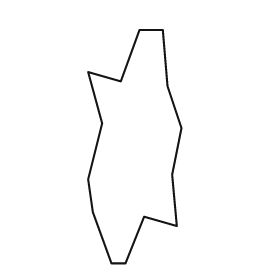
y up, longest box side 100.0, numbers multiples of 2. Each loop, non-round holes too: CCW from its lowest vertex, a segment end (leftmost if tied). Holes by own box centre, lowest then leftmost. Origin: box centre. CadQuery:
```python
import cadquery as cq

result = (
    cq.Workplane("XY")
    .moveTo(-10.0, -50.0)
    .lineTo(-4.0, -50.0)
    .lineTo(4.0, -30.0)
    .lineTo(18.0, -34.0)
    .lineTo(16.0, -12.0)
    .lineTo(20.0, 8.0)
    .lineTo(14.0, 26.0)
    .lineTo(12.0, 50.0)
    .lineTo(2.0, 50.0)
    .lineTo(-6.0, 28.0)
    .lineTo(-20.0, 32.0)
    .lineTo(-14.0, 10.0)
    .lineTo(-20.0, -14.0)
    .lineTo(-18.0, -28.0)
    .close()
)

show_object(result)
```